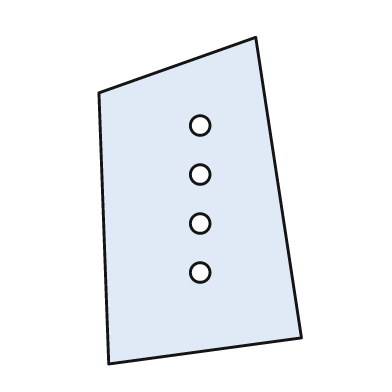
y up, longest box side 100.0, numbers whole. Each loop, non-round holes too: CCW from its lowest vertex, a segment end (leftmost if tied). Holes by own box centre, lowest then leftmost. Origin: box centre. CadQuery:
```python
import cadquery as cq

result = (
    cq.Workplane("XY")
    .moveTo(-28.0, -50.0)
    .lineTo(31.0, -42.0)
    .lineTo(17.0, 50.0)
    .lineTo(-31.0, 33.0)
    .close()
    .moveTo(0.0, -22.0)
    .circle(3.0)
    .moveTo(0.0, -7.0)
    .circle(3.0)
    .moveTo(0.0, 8.0)
    .circle(3.0)
    .moveTo(0.0, 23.0)
    .circle(3.0)
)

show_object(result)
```